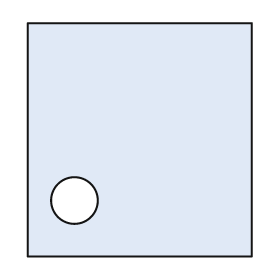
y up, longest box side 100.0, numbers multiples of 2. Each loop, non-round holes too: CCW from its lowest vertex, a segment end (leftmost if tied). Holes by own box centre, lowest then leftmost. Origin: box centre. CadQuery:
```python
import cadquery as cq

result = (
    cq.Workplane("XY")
    .moveTo(-48.0, -50.0)
    .lineTo(48.0, -50.0)
    .lineTo(48.0, 50.0)
    .lineTo(-48.0, 50.0)
    .close()
    .moveTo(-28.0, -26.0)
    .circle(10.0)
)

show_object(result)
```